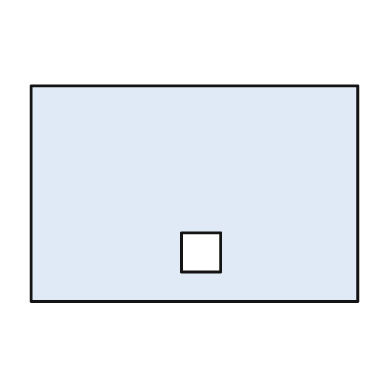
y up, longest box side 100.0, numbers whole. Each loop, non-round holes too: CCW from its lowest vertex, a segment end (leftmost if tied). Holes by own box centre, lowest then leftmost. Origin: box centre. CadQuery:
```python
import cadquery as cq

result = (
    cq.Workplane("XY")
    .moveTo(-50.0, -33.0)
    .lineTo(50.0, -33.0)
    .lineTo(50.0, 33.0)
    .lineTo(-50.0, 33.0)
    .close()
    .moveTo(-4.0, -24.0)
    .lineTo(8.0, -24.0)
    .lineTo(8.0, -12.0)
    .lineTo(-4.0, -12.0)
    .close()
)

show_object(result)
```